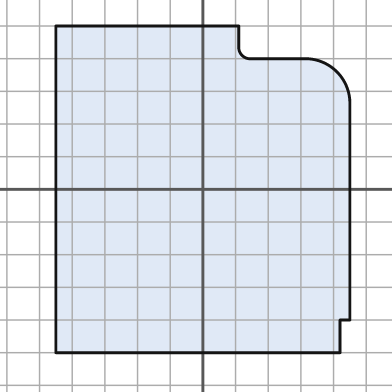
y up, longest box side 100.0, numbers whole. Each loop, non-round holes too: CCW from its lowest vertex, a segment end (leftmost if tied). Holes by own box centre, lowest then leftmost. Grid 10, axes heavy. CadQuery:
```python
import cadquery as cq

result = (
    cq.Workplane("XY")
    .moveTo(-45.0, -50.0)
    .lineTo(42.0, -50.0)
    .lineTo(42.0, -40.0)
    .lineTo(45.0, -40.0)
    .lineTo(45.0, 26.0)
    .threePointArc((41.0, 36.0), (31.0, 40.0))
    .lineTo(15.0, 40.0)
    .threePointArc((12.0, 41.0), (11.0, 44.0))
    .lineTo(11.0, 50.0)
    .lineTo(-45.0, 50.0)
    .close()
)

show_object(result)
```